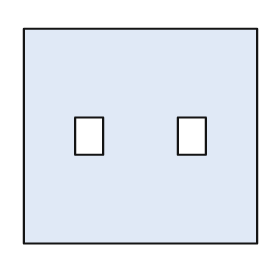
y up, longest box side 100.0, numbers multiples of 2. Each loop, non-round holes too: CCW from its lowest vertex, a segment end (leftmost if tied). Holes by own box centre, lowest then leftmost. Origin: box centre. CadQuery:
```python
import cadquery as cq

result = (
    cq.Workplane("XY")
    .moveTo(-50.0, -46.0)
    .lineTo(50.0, -46.0)
    .lineTo(50.0, 46.0)
    .lineTo(-50.0, 46.0)
    .close()
    .moveTo(-28.0, -8.0)
    .lineTo(-16.0, -8.0)
    .lineTo(-16.0, 8.0)
    .lineTo(-28.0, 8.0)
    .close()
    .moveTo(16.0, -8.0)
    .lineTo(28.0, -8.0)
    .lineTo(28.0, 8.0)
    .lineTo(16.0, 8.0)
    .close()
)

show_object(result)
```